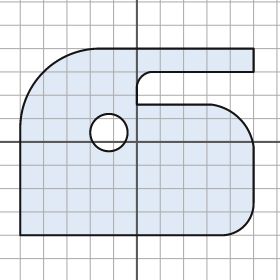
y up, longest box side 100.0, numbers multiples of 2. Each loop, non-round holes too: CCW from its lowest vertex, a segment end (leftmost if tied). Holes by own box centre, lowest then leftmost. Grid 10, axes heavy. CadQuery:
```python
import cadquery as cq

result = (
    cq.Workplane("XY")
    .moveTo(-50.0, -40.0)
    .lineTo(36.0, -40.0)
    .threePointArc((46.0, -36.0), (50.0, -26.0))
    .lineTo(50.0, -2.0)
    .threePointArc((44.0, 10.0), (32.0, 16.0))
    .lineTo(0.0, 16.0)
    .lineTo(0.0, 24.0)
    .threePointArc((2.0, 28.0), (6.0, 30.0))
    .lineTo(50.0, 30.0)
    .lineTo(50.0, 40.0)
    .lineTo(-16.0, 40.0)
    .threePointArc((-40.0, 30.0), (-50.0, 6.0))
    .close()
    .moveTo(-12.0, 4.0)
    .circle(8.0)
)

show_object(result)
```